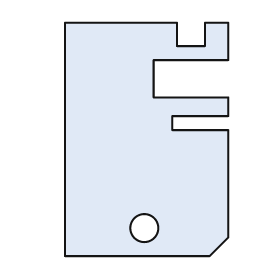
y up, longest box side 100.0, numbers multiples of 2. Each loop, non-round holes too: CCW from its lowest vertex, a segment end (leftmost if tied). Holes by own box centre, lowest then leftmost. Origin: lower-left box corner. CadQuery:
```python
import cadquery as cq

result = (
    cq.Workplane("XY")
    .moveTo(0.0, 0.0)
    .lineTo(62.0, 0.0)
    .lineTo(70.0, 8.0)
    .lineTo(70.0, 54.0)
    .lineTo(46.0, 54.0)
    .lineTo(46.0, 60.0)
    .lineTo(70.0, 60.0)
    .lineTo(70.0, 68.0)
    .lineTo(38.0, 68.0)
    .lineTo(38.0, 84.0)
    .lineTo(70.0, 84.0)
    .lineTo(70.0, 100.0)
    .lineTo(60.0, 100.0)
    .lineTo(60.0, 90.0)
    .lineTo(48.0, 90.0)
    .lineTo(48.0, 100.0)
    .lineTo(0.0, 100.0)
    .close()
    .moveTo(34.0, 12.0)
    .circle(6.0)
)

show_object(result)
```